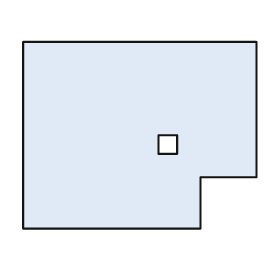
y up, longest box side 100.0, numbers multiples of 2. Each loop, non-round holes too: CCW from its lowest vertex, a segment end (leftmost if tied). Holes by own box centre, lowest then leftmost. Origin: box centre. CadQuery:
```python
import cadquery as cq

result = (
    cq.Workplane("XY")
    .moveTo(-50.0, -40.0)
    .lineTo(26.0, -40.0)
    .lineTo(26.0, -18.0)
    .lineTo(50.0, -18.0)
    .lineTo(50.0, 40.0)
    .lineTo(-50.0, 40.0)
    .close()
    .moveTo(8.0, -8.0)
    .lineTo(16.0, -8.0)
    .lineTo(16.0, 0.0)
    .lineTo(8.0, 0.0)
    .close()
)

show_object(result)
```